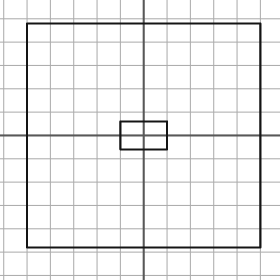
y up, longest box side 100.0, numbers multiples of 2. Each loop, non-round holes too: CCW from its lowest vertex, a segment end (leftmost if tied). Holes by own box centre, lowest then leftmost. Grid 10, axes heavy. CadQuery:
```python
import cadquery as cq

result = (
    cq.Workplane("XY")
    .moveTo(-50.0, -48.0)
    .lineTo(50.0, -48.0)
    .lineTo(50.0, 48.0)
    .lineTo(-50.0, 48.0)
    .close()
    .moveTo(-10.0, -6.0)
    .lineTo(10.0, -6.0)
    .lineTo(10.0, 6.0)
    .lineTo(-10.0, 6.0)
    .close()
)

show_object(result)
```